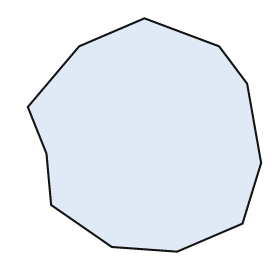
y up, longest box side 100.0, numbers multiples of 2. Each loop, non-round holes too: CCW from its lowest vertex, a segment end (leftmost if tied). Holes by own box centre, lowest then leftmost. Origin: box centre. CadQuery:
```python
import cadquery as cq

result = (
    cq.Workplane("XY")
    .moveTo(14.0, -50.0)
    .lineTo(42.0, -38.0)
    .lineTo(50.0, -12.0)
    .lineTo(44.0, 22.0)
    .lineTo(32.0, 38.0)
    .lineTo(0.0, 50.0)
    .lineTo(-28.0, 38.0)
    .lineTo(-50.0, 12.0)
    .lineTo(-42.0, -8.0)
    .lineTo(-40.0, -30.0)
    .lineTo(-14.0, -48.0)
    .close()
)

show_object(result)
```